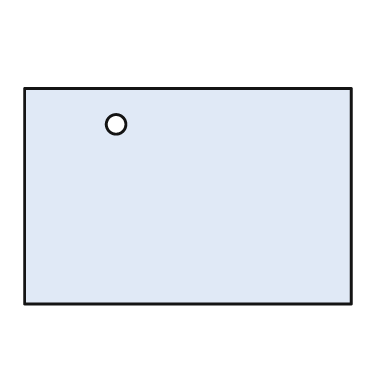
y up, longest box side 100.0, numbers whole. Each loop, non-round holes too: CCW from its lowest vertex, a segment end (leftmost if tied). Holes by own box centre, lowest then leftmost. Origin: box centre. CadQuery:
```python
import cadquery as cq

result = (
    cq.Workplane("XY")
    .moveTo(-50.0, -33.0)
    .lineTo(50.0, -33.0)
    .lineTo(50.0, 33.0)
    .lineTo(-50.0, 33.0)
    .close()
    .moveTo(-22.0, 22.0)
    .circle(3.0)
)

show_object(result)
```